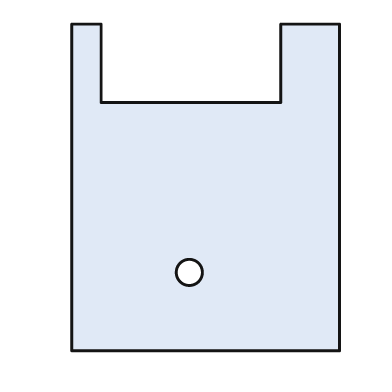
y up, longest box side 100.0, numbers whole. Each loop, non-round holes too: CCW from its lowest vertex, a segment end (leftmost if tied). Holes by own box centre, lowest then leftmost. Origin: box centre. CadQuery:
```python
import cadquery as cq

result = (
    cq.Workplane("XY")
    .moveTo(-41.0, -50.0)
    .lineTo(41.0, -50.0)
    .lineTo(41.0, 50.0)
    .lineTo(23.0, 50.0)
    .lineTo(23.0, 26.0)
    .lineTo(-32.0, 26.0)
    .lineTo(-32.0, 50.0)
    .lineTo(-41.0, 50.0)
    .close()
    .moveTo(-5.0, -26.0)
    .circle(4.0)
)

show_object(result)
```